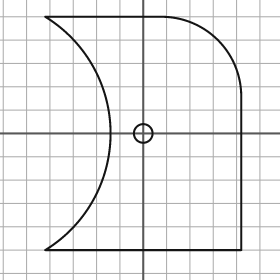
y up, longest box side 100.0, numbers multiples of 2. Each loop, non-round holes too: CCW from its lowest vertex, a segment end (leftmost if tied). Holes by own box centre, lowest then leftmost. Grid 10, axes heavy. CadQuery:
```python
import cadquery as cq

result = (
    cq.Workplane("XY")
    .moveTo(-42.0, -50.0)
    .lineTo(42.0, -50.0)
    .lineTo(42.0, 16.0)
    .threePointArc((32.0, 40.0), (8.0, 50.0))
    .lineTo(-42.0, 50.0)
    .threePointArc((-14.0, 0.0), (-42.0, -50.0))
    .close()
    .moveTo(0.0, 0.0)
    .circle(4.0)
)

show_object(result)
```